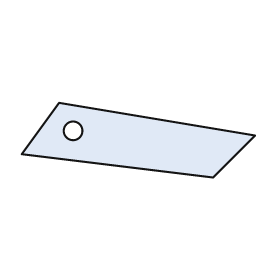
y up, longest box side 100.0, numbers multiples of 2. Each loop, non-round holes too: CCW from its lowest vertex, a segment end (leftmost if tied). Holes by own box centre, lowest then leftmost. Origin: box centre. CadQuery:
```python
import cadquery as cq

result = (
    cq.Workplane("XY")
    .moveTo(32.0, -16.0)
    .lineTo(50.0, 2.0)
    .lineTo(-34.0, 16.0)
    .lineTo(-50.0, -6.0)
    .close()
    .moveTo(-28.0, 4.0)
    .circle(4.0)
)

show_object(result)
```